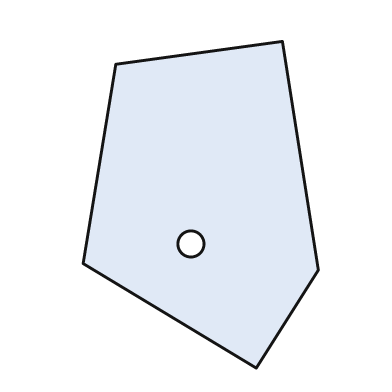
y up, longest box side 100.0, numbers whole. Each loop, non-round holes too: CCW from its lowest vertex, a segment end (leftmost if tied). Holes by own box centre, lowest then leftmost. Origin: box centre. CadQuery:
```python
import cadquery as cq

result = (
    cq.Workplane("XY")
    .moveTo(17.0, -50.0)
    .lineTo(36.0, -20.0)
    .lineTo(25.0, 50.0)
    .lineTo(-26.0, 43.0)
    .lineTo(-36.0, -18.0)
    .close()
    .moveTo(-3.0, -12.0)
    .circle(4.0)
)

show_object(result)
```